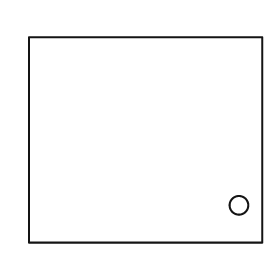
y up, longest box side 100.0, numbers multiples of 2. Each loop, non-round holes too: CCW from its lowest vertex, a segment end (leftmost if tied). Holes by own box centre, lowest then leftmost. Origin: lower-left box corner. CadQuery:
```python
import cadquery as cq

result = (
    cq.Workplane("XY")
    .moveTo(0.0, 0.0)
    .lineTo(100.0, 0.0)
    .lineTo(100.0, 88.0)
    .lineTo(0.0, 88.0)
    .close()
    .moveTo(90.0, 16.0)
    .circle(4.0)
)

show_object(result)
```